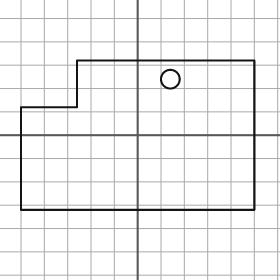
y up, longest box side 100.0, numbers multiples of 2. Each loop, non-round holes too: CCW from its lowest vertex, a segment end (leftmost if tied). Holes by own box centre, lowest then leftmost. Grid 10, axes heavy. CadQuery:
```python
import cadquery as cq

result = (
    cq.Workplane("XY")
    .moveTo(-50.0, -32.0)
    .lineTo(50.0, -32.0)
    .lineTo(50.0, 32.0)
    .lineTo(-26.0, 32.0)
    .lineTo(-26.0, 12.0)
    .lineTo(-50.0, 12.0)
    .close()
    .moveTo(14.0, 24.0)
    .circle(4.0)
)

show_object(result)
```